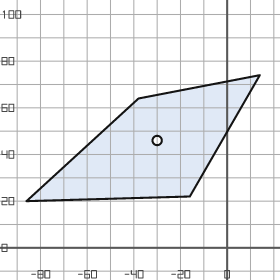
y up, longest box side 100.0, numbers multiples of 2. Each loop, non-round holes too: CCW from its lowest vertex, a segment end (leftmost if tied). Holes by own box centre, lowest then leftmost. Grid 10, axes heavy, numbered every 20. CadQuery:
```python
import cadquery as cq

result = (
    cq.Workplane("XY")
    .moveTo(-86.0, 20.0)
    .lineTo(-16.0, 22.0)
    .lineTo(14.0, 74.0)
    .lineTo(-38.0, 64.0)
    .close()
    .moveTo(-30.0, 46.0)
    .circle(2.0)
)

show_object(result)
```